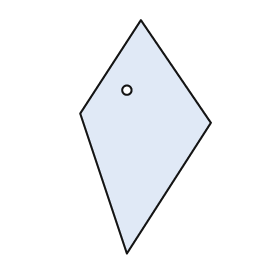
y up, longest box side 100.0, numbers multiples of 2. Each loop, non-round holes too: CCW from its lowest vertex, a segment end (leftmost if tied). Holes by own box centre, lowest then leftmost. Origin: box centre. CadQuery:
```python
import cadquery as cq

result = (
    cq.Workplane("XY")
    .moveTo(-8.0, -50.0)
    .lineTo(28.0, 6.0)
    .lineTo(-2.0, 50.0)
    .lineTo(-28.0, 10.0)
    .close()
    .moveTo(-8.0, 20.0)
    .circle(2.0)
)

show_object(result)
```